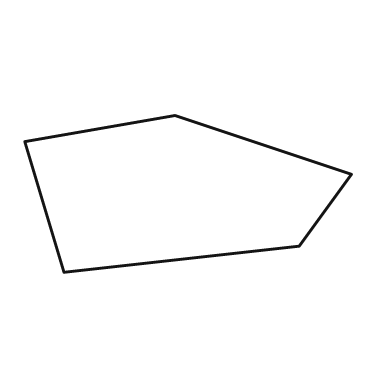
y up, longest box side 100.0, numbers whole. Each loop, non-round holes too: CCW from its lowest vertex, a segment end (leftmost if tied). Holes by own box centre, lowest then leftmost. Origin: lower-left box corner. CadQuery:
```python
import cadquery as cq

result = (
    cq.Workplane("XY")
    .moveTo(12.0, 0.0)
    .lineTo(84.0, 8.0)
    .lineTo(100.0, 30.0)
    .lineTo(46.0, 48.0)
    .lineTo(0.0, 40.0)
    .close()
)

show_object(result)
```